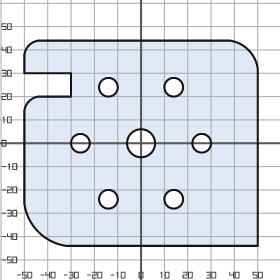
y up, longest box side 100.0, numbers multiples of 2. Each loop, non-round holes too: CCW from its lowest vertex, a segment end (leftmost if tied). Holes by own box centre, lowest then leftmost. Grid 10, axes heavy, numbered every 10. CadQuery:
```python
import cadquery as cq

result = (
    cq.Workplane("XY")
    .moveTo(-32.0, -44.0)
    .lineTo(50.0, -44.0)
    .lineTo(50.0, 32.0)
    .threePointArc((46.0, 40.0), (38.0, 44.0))
    .lineTo(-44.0, 44.0)
    .threePointArc((-48.0, 42.0), (-50.0, 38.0))
    .lineTo(-50.0, 30.0)
    .lineTo(-30.0, 30.0)
    .lineTo(-30.0, 20.0)
    .lineTo(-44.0, 20.0)
    .threePointArc((-48.0, 18.0), (-50.0, 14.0))
    .lineTo(-50.0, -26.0)
    .threePointArc((-44.0, -38.0), (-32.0, -44.0))
    .close()
    .moveTo(-14.0, -24.0)
    .circle(4.0)
    .moveTo(14.0, -24.0)
    .circle(4.0)
    .moveTo(-26.0, 0.0)
    .circle(4.0)
    .moveTo(0.0, 0.0)
    .circle(6.0)
    .moveTo(26.0, 0.0)
    .circle(4.0)
    .moveTo(-14.0, 24.0)
    .circle(4.0)
    .moveTo(14.0, 24.0)
    .circle(4.0)
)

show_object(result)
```